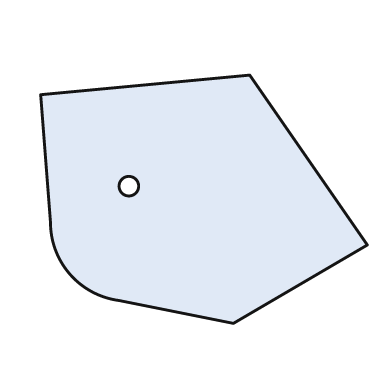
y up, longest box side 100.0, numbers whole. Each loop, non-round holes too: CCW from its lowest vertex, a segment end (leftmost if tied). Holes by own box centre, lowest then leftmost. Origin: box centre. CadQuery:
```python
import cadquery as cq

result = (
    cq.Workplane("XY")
    .moveTo(9.0, -38.0)
    .lineTo(50.0, -14.0)
    .lineTo(14.0, 38.0)
    .lineTo(-50.0, 32.0)
    .lineTo(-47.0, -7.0)
    .threePointArc((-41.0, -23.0), (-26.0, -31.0))
    .close()
    .moveTo(-23.0, 4.0)
    .circle(3.0)
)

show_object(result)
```